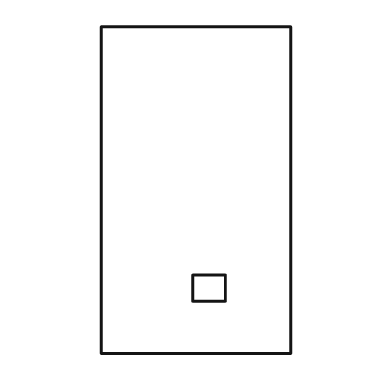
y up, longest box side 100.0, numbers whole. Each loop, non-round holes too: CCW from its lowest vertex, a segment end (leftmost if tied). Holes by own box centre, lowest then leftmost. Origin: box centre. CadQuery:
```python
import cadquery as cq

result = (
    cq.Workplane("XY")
    .moveTo(-29.0, -50.0)
    .lineTo(29.0, -50.0)
    .lineTo(29.0, 50.0)
    .lineTo(-29.0, 50.0)
    .close()
    .moveTo(-1.0, -34.0)
    .lineTo(9.0, -34.0)
    .lineTo(9.0, -26.0)
    .lineTo(-1.0, -26.0)
    .close()
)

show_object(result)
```